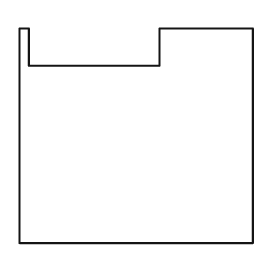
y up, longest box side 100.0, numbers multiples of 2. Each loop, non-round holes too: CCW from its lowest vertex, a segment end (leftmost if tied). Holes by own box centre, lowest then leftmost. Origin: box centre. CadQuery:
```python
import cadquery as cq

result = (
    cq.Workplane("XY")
    .moveTo(-50.0, -46.0)
    .lineTo(50.0, -46.0)
    .lineTo(50.0, 46.0)
    .lineTo(10.0, 46.0)
    .lineTo(10.0, 30.0)
    .lineTo(-46.0, 30.0)
    .lineTo(-46.0, 46.0)
    .lineTo(-50.0, 46.0)
    .close()
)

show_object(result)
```